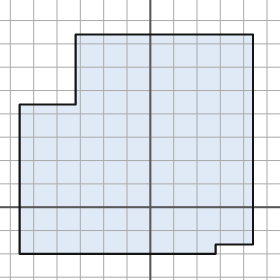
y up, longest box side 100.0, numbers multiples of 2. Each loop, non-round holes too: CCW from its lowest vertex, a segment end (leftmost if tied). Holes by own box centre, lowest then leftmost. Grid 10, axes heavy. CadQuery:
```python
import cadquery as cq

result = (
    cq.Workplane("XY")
    .moveTo(-56.0, -20.0)
    .lineTo(28.0, -20.0)
    .lineTo(28.0, -16.0)
    .lineTo(44.0, -16.0)
    .lineTo(44.0, 74.0)
    .lineTo(-32.0, 74.0)
    .lineTo(-32.0, 44.0)
    .lineTo(-56.0, 44.0)
    .close()
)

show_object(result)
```